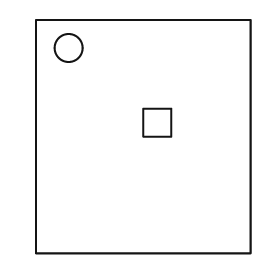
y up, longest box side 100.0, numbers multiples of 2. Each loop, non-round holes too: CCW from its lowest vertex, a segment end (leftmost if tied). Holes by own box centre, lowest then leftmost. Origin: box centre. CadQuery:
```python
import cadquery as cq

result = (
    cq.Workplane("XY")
    .moveTo(-46.0, -50.0)
    .lineTo(46.0, -50.0)
    .lineTo(46.0, 50.0)
    .lineTo(-46.0, 50.0)
    .close()
    .moveTo(0.0, 0.0)
    .lineTo(12.0, 0.0)
    .lineTo(12.0, 12.0)
    .lineTo(0.0, 12.0)
    .close()
    .moveTo(-32.0, 38.0)
    .circle(6.0)
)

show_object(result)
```